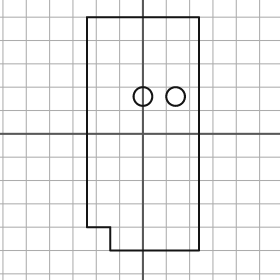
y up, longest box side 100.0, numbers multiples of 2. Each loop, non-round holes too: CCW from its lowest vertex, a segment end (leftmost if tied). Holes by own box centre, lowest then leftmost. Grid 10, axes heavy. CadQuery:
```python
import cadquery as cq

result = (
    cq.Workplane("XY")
    .moveTo(-14.0, -50.0)
    .lineTo(24.0, -50.0)
    .lineTo(24.0, 50.0)
    .lineTo(-24.0, 50.0)
    .lineTo(-24.0, -40.0)
    .lineTo(-14.0, -40.0)
    .close()
    .moveTo(0.0, 16.0)
    .circle(4.0)
    .moveTo(14.0, 16.0)
    .circle(4.0)
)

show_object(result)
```